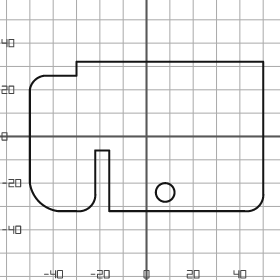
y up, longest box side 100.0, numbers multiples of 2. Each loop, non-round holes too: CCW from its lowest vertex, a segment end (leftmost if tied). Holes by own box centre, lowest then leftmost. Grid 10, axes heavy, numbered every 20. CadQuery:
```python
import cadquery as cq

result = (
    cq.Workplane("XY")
    .moveTo(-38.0, -32.0)
    .lineTo(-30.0, -32.0)
    .threePointArc((-24.0, -30.0), (-22.0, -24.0))
    .lineTo(-22.0, -6.0)
    .lineTo(-16.0, -6.0)
    .lineTo(-16.0, -32.0)
    .lineTo(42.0, -32.0)
    .threePointArc((48.0, -30.0), (50.0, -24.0))
    .lineTo(50.0, 32.0)
    .lineTo(-30.0, 32.0)
    .lineTo(-30.0, 26.0)
    .lineTo(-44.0, 26.0)
    .threePointArc((-48.0, 24.0), (-50.0, 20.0))
    .lineTo(-50.0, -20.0)
    .threePointArc((-46.0, -28.0), (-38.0, -32.0))
    .close()
    .moveTo(8.0, -24.0)
    .circle(4.0)
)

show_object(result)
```